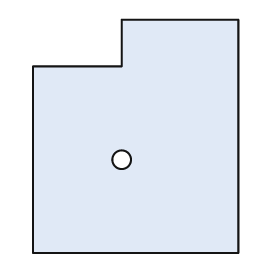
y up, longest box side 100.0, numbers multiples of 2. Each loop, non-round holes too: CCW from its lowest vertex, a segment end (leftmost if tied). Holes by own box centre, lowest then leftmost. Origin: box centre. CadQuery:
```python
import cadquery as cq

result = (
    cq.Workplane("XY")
    .moveTo(-44.0, -50.0)
    .lineTo(44.0, -50.0)
    .lineTo(44.0, 50.0)
    .lineTo(-6.0, 50.0)
    .lineTo(-6.0, 30.0)
    .lineTo(-44.0, 30.0)
    .close()
    .moveTo(-6.0, -10.0)
    .circle(4.0)
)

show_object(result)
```